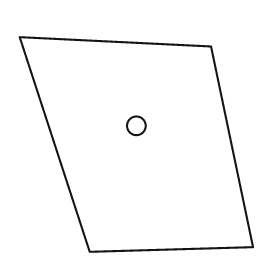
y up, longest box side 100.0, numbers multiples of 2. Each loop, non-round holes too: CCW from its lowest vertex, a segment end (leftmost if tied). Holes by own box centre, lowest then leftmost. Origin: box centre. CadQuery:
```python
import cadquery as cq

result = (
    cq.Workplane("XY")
    .moveTo(-20.0, -46.0)
    .lineTo(50.0, -44.0)
    .lineTo(32.0, 42.0)
    .lineTo(-50.0, 46.0)
    .close()
    .moveTo(0.0, 8.0)
    .circle(4.0)
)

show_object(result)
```